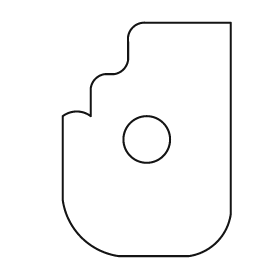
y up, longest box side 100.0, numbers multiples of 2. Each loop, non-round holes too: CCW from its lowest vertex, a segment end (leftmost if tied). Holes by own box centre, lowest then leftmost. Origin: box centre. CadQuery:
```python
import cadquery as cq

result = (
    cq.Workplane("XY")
    .moveTo(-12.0, -50.0)
    .lineTo(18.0, -50.0)
    .threePointArc((30.0, -44.0), (36.0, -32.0))
    .lineTo(36.0, 50.0)
    .lineTo(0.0, 50.0)
    .threePointArc((-6.0, 48.0), (-8.0, 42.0))
    .lineTo(-8.0, 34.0)
    .threePointArc((-10.0, 30.0), (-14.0, 28.0))
    .lineTo(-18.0, 28.0)
    .threePointArc((-22.0, 26.0), (-24.0, 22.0))
    .lineTo(-24.0, 10.0)
    .threePointArc((-30.0, 12.0), (-36.0, 10.0))
    .lineTo(-36.0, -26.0)
    .threePointArc((-28.0, -42.0), (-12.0, -50.0))
    .close()
    .moveTo(0.0, 0.0)
    .circle(10.0)
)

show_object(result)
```